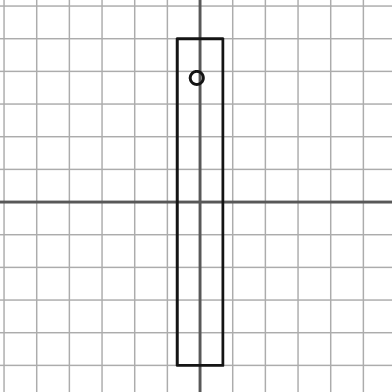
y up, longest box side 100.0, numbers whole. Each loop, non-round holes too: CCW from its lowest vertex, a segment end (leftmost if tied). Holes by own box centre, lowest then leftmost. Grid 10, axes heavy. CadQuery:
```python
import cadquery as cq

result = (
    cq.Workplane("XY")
    .moveTo(-7.0, -50.0)
    .lineTo(7.0, -50.0)
    .lineTo(7.0, 50.0)
    .lineTo(-7.0, 50.0)
    .close()
    .moveTo(-1.0, 38.0)
    .circle(2.0)
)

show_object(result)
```